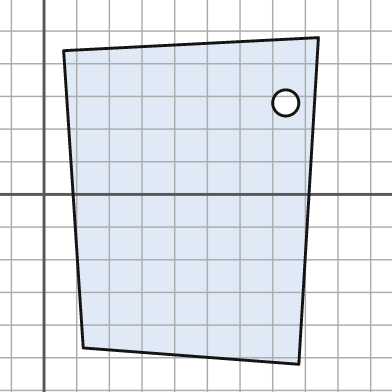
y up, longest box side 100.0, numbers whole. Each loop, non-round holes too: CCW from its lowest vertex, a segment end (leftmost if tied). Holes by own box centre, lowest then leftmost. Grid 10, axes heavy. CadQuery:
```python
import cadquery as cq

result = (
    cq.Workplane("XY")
    .moveTo(78.0, -52.0)
    .lineTo(84.0, 48.0)
    .lineTo(6.0, 44.0)
    .lineTo(12.0, -47.0)
    .close()
    .moveTo(74.0, 28.0)
    .circle(4.0)
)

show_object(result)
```